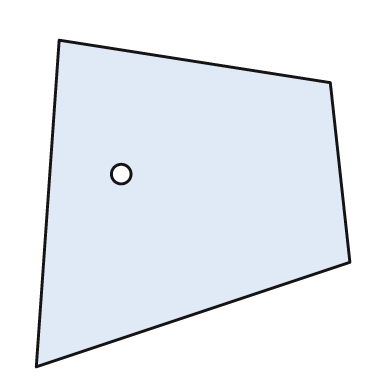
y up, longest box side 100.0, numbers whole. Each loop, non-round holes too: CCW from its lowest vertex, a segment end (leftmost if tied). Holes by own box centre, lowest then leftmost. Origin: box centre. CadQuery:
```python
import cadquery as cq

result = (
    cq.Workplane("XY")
    .moveTo(-48.0, -50.0)
    .lineTo(48.0, -18.0)
    .lineTo(42.0, 37.0)
    .lineTo(-41.0, 50.0)
    .close()
    .moveTo(-22.0, 9.0)
    .circle(3.0)
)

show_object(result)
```